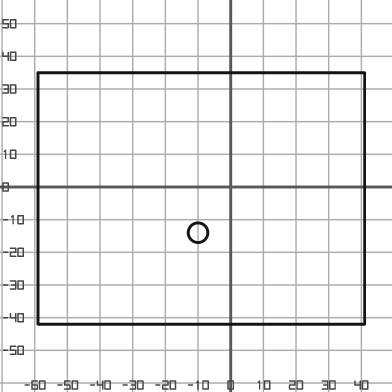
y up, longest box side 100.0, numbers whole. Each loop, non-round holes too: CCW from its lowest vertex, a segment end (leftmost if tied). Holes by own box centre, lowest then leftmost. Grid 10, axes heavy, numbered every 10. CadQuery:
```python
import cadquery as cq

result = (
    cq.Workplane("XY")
    .moveTo(-59.0, -42.0)
    .lineTo(41.0, -42.0)
    .lineTo(41.0, 35.0)
    .lineTo(-59.0, 35.0)
    .close()
    .moveTo(-10.0, -14.0)
    .circle(3.0)
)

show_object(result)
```